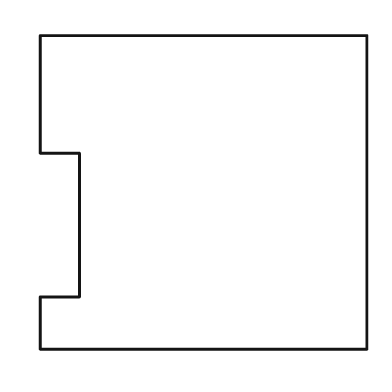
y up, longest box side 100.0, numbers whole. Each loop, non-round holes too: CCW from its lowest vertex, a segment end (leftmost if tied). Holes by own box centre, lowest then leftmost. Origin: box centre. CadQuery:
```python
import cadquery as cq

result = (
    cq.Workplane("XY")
    .moveTo(-50.0, -48.0)
    .lineTo(50.0, -48.0)
    .lineTo(50.0, 48.0)
    .lineTo(-50.0, 48.0)
    .lineTo(-50.0, 12.0)
    .lineTo(-38.0, 12.0)
    .lineTo(-38.0, -32.0)
    .lineTo(-50.0, -32.0)
    .close()
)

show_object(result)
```